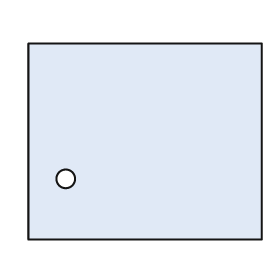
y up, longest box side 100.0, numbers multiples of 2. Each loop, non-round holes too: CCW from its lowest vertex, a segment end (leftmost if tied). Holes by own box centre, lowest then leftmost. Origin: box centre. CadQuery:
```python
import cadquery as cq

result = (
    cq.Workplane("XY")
    .moveTo(-50.0, -42.0)
    .lineTo(50.0, -42.0)
    .lineTo(50.0, 42.0)
    .lineTo(-50.0, 42.0)
    .close()
    .moveTo(-34.0, -16.0)
    .circle(4.0)
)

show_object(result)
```